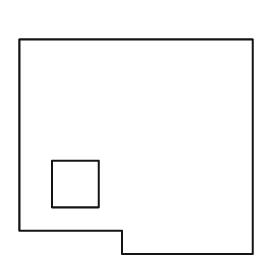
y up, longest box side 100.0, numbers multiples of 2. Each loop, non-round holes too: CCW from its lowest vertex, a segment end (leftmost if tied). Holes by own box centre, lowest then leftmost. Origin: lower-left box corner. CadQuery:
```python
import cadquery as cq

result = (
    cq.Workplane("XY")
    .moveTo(44.0, 0.0)
    .lineTo(100.0, 0.0)
    .lineTo(100.0, 92.0)
    .lineTo(0.0, 92.0)
    .lineTo(0.0, 10.0)
    .lineTo(44.0, 10.0)
    .close()
    .moveTo(14.0, 20.0)
    .lineTo(34.0, 20.0)
    .lineTo(34.0, 40.0)
    .lineTo(14.0, 40.0)
    .close()
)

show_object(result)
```